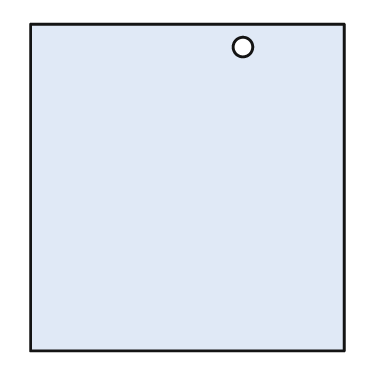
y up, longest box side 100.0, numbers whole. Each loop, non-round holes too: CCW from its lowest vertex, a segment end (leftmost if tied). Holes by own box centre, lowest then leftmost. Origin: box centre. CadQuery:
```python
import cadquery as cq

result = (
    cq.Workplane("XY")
    .moveTo(-48.0, -50.0)
    .lineTo(48.0, -50.0)
    .lineTo(48.0, 50.0)
    .lineTo(-48.0, 50.0)
    .close()
    .moveTo(17.0, 43.0)
    .circle(3.0)
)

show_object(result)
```